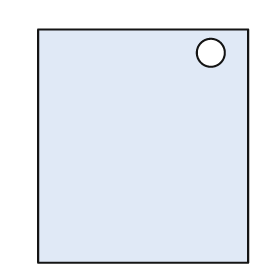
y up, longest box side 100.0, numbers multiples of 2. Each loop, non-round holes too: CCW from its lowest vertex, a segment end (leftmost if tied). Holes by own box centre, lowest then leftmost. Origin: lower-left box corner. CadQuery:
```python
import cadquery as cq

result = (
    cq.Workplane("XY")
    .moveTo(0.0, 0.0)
    .lineTo(90.0, 0.0)
    .lineTo(90.0, 100.0)
    .lineTo(0.0, 100.0)
    .close()
    .moveTo(74.0, 90.0)
    .circle(6.0)
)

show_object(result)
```